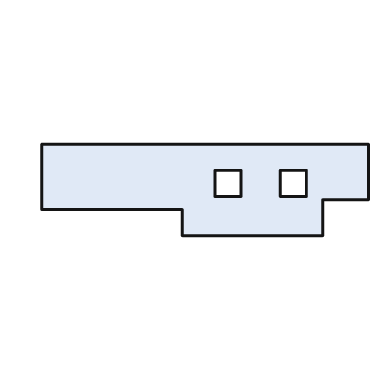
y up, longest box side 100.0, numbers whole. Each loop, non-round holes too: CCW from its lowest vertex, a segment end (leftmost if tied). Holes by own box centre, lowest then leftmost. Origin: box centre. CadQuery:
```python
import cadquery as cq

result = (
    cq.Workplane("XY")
    .moveTo(-7.0, -14.0)
    .lineTo(36.0, -14.0)
    .lineTo(36.0, -3.0)
    .lineTo(50.0, -3.0)
    .lineTo(50.0, 14.0)
    .lineTo(-50.0, 14.0)
    .lineTo(-50.0, -6.0)
    .lineTo(-7.0, -6.0)
    .close()
    .moveTo(3.0, -2.0)
    .lineTo(11.0, -2.0)
    .lineTo(11.0, 6.0)
    .lineTo(3.0, 6.0)
    .close()
    .moveTo(23.0, -2.0)
    .lineTo(31.0, -2.0)
    .lineTo(31.0, 6.0)
    .lineTo(23.0, 6.0)
    .close()
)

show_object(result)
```